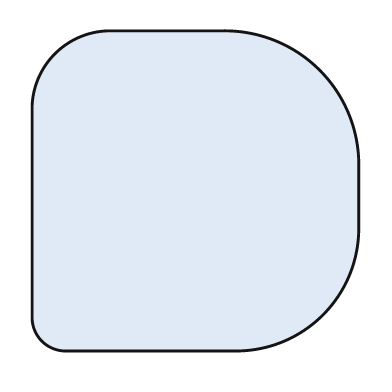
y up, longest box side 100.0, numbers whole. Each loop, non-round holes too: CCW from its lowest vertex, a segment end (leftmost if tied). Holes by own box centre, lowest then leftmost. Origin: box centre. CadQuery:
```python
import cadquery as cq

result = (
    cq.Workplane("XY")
    .moveTo(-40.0, -49.0)
    .lineTo(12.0, -49.0)
    .threePointArc((39.0, -38.0), (50.0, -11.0))
    .lineTo(50.0, 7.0)
    .threePointArc((38.0, 37.0), (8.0, 49.0))
    .lineTo(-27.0, 49.0)
    .threePointArc((-43.0, 42.0), (-50.0, 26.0))
    .lineTo(-50.0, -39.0)
    .threePointArc((-47.0, -46.0), (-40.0, -49.0))
    .close()
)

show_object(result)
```